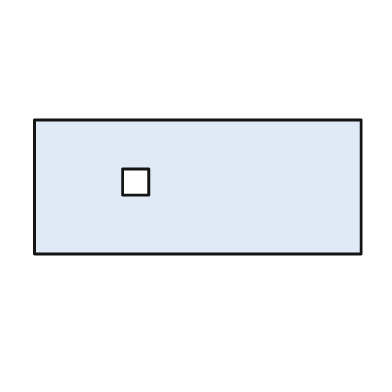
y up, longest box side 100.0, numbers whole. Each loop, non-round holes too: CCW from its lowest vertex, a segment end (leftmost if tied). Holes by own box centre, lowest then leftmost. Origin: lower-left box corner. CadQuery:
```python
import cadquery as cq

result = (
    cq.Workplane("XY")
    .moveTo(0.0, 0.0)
    .lineTo(100.0, 0.0)
    .lineTo(100.0, 41.0)
    .lineTo(0.0, 41.0)
    .close()
    .moveTo(27.0, 18.0)
    .lineTo(35.0, 18.0)
    .lineTo(35.0, 26.0)
    .lineTo(27.0, 26.0)
    .close()
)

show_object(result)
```